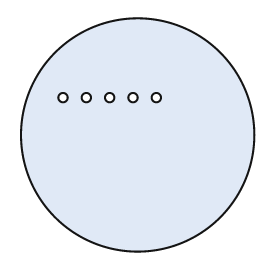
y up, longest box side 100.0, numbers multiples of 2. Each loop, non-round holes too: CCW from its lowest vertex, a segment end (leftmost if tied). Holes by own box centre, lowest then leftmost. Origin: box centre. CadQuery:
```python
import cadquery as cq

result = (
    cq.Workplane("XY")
    .moveTo(0.0, 0.0)
    .circle(50.0)
    .moveTo(-32.0, 16.0)
    .circle(2.0)
    .moveTo(-22.0, 16.0)
    .circle(2.0)
    .moveTo(-12.0, 16.0)
    .circle(2.0)
    .moveTo(-2.0, 16.0)
    .circle(2.0)
    .moveTo(8.0, 16.0)
    .circle(2.0)
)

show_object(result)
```